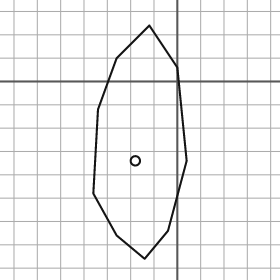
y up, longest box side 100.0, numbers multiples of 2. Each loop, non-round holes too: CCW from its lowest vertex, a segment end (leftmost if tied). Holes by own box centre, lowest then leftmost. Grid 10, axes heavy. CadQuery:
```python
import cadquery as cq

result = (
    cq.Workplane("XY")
    .moveTo(-14.0, -76.0)
    .lineTo(-4.0, -64.0)
    .lineTo(4.0, -34.0)
    .lineTo(0.0, 6.0)
    .lineTo(-12.0, 24.0)
    .lineTo(-26.0, 10.0)
    .lineTo(-34.0, -12.0)
    .lineTo(-36.0, -48.0)
    .lineTo(-26.0, -66.0)
    .close()
    .moveTo(-18.0, -34.0)
    .circle(2.0)
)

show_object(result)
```